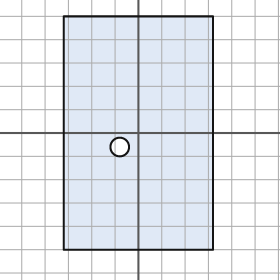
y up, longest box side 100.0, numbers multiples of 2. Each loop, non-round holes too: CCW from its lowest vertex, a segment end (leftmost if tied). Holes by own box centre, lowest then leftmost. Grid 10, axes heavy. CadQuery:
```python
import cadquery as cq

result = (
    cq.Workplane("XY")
    .moveTo(-32.0, -50.0)
    .lineTo(32.0, -50.0)
    .lineTo(32.0, 50.0)
    .lineTo(-32.0, 50.0)
    .close()
    .moveTo(-8.0, -6.0)
    .circle(4.0)
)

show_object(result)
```